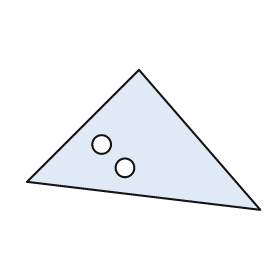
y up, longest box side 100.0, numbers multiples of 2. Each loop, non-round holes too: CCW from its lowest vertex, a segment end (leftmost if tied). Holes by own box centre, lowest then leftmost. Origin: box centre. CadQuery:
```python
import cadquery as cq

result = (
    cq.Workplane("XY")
    .moveTo(50.0, -30.0)
    .lineTo(-2.0, 30.0)
    .lineTo(-50.0, -18.0)
    .close()
    .moveTo(-8.0, -12.0)
    .circle(4.0)
    .moveTo(-18.0, -2.0)
    .circle(4.0)
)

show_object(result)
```